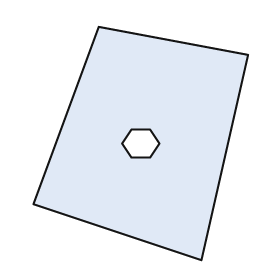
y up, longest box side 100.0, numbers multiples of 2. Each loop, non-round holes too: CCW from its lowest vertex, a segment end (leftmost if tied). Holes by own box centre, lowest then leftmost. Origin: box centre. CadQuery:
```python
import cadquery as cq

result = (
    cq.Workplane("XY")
    .moveTo(26.0, -50.0)
    .lineTo(46.0, 38.0)
    .lineTo(-18.0, 50.0)
    .lineTo(-46.0, -26.0)
    .close()
    .moveTo(-4.0, -6.0)
    .lineTo(4.0, -6.0)
    .lineTo(8.0, 0.0)
    .lineTo(4.0, 6.0)
    .lineTo(-4.0, 6.0)
    .lineTo(-8.0, 0.0)
    .close()
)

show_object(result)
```